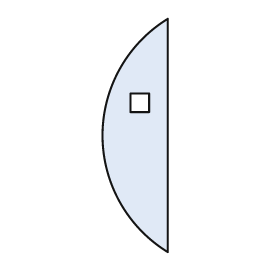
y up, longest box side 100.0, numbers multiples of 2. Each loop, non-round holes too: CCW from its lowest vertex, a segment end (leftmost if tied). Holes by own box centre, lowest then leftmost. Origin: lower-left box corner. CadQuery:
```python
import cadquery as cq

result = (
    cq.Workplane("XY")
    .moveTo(28.0, 0.0)
    .lineTo(28.0, 100.0)
    .threePointArc((0.0, 50.0), (28.0, 0.0))
    .close()
    .moveTo(12.0, 60.0)
    .lineTo(20.0, 60.0)
    .lineTo(20.0, 68.0)
    .lineTo(12.0, 68.0)
    .close()
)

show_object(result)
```